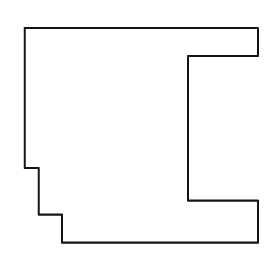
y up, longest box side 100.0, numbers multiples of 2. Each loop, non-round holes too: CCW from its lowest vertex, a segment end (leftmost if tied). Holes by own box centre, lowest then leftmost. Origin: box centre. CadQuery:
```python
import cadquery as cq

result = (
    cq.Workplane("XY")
    .moveTo(-34.0, -46.0)
    .lineTo(50.0, -46.0)
    .lineTo(50.0, -28.0)
    .lineTo(20.0, -28.0)
    .lineTo(20.0, 34.0)
    .lineTo(50.0, 34.0)
    .lineTo(50.0, 46.0)
    .lineTo(-50.0, 46.0)
    .lineTo(-50.0, -14.0)
    .lineTo(-44.0, -14.0)
    .lineTo(-44.0, -34.0)
    .lineTo(-34.0, -34.0)
    .close()
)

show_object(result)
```